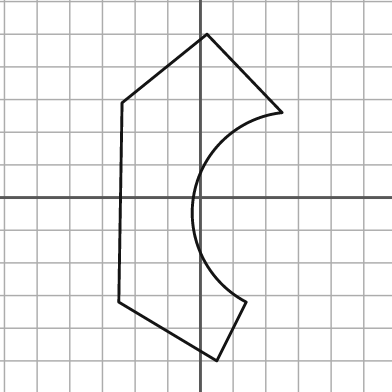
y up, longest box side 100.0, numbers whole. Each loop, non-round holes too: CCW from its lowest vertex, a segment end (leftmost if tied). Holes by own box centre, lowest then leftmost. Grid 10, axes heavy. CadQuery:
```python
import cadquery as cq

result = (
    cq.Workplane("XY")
    .moveTo(5.0, -50.0)
    .lineTo(14.0, -32.0)
    .threePointArc((-2.0, 1.0), (25.0, 26.0))
    .lineTo(2.0, 50.0)
    .lineTo(-24.0, 29.0)
    .lineTo(-25.0, -32.0)
    .close()
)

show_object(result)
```